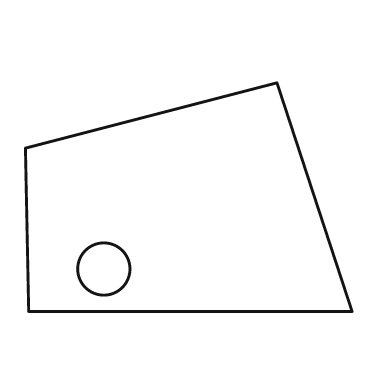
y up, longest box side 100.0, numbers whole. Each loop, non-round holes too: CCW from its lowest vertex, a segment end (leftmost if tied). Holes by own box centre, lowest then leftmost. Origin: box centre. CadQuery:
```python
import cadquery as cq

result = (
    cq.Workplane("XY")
    .moveTo(-49.0, -35.0)
    .lineTo(50.0, -35.0)
    .lineTo(27.0, 35.0)
    .lineTo(-50.0, 15.0)
    .close()
    .moveTo(-26.0, -22.0)
    .circle(8.0)
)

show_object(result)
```